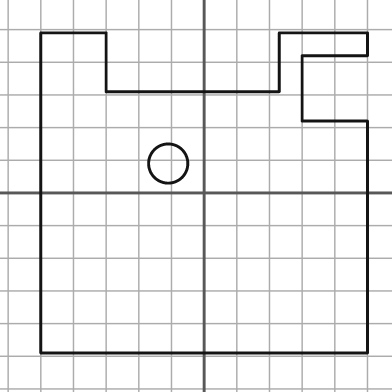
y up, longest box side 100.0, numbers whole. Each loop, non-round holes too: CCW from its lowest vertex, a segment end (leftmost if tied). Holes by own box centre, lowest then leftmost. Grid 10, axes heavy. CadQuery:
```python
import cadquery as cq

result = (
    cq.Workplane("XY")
    .moveTo(-50.0, -49.0)
    .lineTo(50.0, -49.0)
    .lineTo(50.0, 22.0)
    .lineTo(30.0, 22.0)
    .lineTo(30.0, 42.0)
    .lineTo(50.0, 42.0)
    .lineTo(50.0, 49.0)
    .lineTo(23.0, 49.0)
    .lineTo(23.0, 31.0)
    .lineTo(-30.0, 31.0)
    .lineTo(-30.0, 49.0)
    .lineTo(-50.0, 49.0)
    .close()
    .moveTo(-11.0, 9.0)
    .circle(6.0)
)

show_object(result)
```